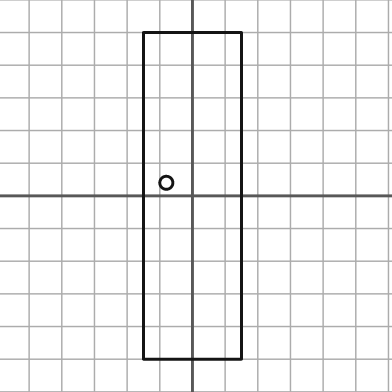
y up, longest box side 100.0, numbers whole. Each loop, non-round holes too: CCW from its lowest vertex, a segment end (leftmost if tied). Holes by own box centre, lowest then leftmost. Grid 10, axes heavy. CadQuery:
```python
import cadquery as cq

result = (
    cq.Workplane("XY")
    .moveTo(-15.0, -50.0)
    .lineTo(15.0, -50.0)
    .lineTo(15.0, 50.0)
    .lineTo(-15.0, 50.0)
    .close()
    .moveTo(-8.0, 4.0)
    .circle(2.0)
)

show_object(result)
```